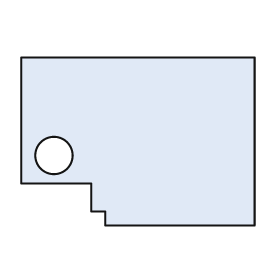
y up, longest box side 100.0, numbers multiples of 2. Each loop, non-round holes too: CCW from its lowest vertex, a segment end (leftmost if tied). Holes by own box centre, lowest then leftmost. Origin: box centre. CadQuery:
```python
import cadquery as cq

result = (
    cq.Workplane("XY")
    .moveTo(-14.0, -36.0)
    .lineTo(50.0, -36.0)
    .lineTo(50.0, 36.0)
    .lineTo(-50.0, 36.0)
    .lineTo(-50.0, -18.0)
    .lineTo(-20.0, -18.0)
    .lineTo(-20.0, -30.0)
    .lineTo(-14.0, -30.0)
    .close()
    .moveTo(-36.0, -6.0)
    .circle(8.0)
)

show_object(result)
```